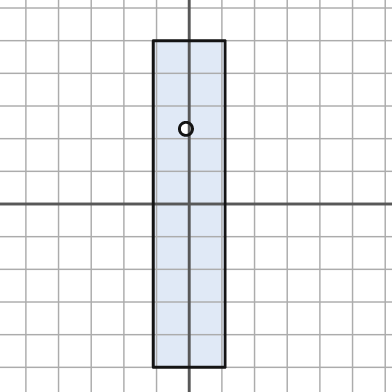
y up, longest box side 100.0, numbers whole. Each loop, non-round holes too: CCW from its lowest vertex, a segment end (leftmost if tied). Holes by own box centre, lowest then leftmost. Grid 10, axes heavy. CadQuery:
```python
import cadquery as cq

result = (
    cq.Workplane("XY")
    .moveTo(-11.0, -50.0)
    .lineTo(11.0, -50.0)
    .lineTo(11.0, 50.0)
    .lineTo(-11.0, 50.0)
    .close()
    .moveTo(-1.0, 23.0)
    .circle(2.0)
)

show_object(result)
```